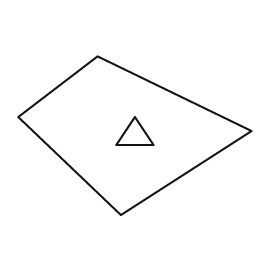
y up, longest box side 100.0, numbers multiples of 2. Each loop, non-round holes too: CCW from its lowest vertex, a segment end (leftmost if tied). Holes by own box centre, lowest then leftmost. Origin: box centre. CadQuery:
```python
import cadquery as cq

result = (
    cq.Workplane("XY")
    .moveTo(-6.0, -34.0)
    .lineTo(50.0, 2.0)
    .lineTo(-16.0, 34.0)
    .lineTo(-50.0, 8.0)
    .close()
    .moveTo(-8.0, -4.0)
    .lineTo(8.0, -4.0)
    .lineTo(0.0, 8.0)
    .close()
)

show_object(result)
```